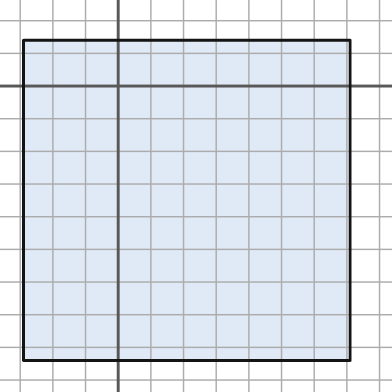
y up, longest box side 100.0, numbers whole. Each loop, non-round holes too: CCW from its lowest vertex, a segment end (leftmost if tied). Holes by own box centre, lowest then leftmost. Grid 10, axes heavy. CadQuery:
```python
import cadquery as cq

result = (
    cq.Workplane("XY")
    .moveTo(-29.0, -84.0)
    .lineTo(71.0, -84.0)
    .lineTo(71.0, 14.0)
    .lineTo(-29.0, 14.0)
    .close()
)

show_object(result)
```